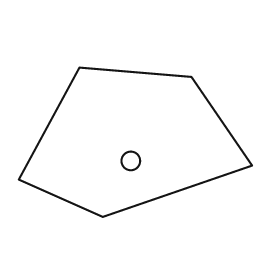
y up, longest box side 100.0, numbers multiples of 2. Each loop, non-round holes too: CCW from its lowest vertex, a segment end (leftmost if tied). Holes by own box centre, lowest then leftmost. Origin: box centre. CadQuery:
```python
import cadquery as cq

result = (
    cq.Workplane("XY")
    .moveTo(-14.0, -32.0)
    .lineTo(50.0, -10.0)
    .lineTo(24.0, 28.0)
    .lineTo(-24.0, 32.0)
    .lineTo(-50.0, -16.0)
    .close()
    .moveTo(-2.0, -8.0)
    .circle(4.0)
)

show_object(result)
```